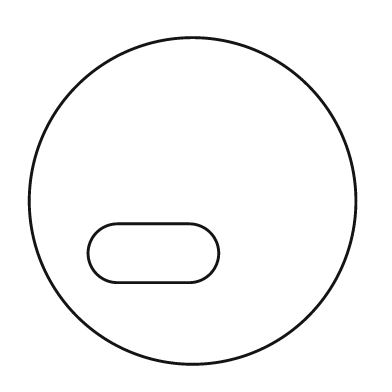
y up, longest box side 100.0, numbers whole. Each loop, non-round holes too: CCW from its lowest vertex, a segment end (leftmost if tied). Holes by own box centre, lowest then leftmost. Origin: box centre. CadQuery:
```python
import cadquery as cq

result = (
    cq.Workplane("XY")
    .moveTo(0.0, 0.0)
    .circle(50.0)
    .moveTo(-23.0, -25.0)
    .lineTo(-1.0, -25.0)
    .threePointArc((8.0, -16.0), (-1.0, -7.0))
    .lineTo(-23.0, -7.0)
    .threePointArc((-32.0, -16.0), (-23.0, -25.0))
    .close()
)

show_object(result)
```